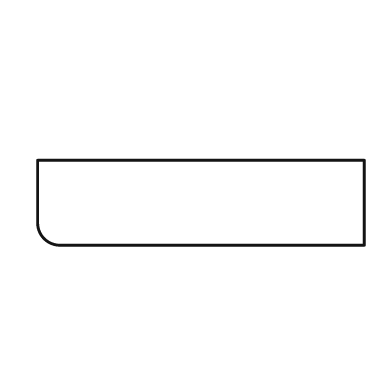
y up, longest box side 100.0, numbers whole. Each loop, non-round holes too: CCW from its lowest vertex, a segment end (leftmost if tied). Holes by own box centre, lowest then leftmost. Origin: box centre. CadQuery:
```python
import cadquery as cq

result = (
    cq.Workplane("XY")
    .moveTo(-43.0, -13.0)
    .lineTo(50.0, -13.0)
    .lineTo(50.0, 13.0)
    .lineTo(-50.0, 13.0)
    .lineTo(-50.0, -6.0)
    .threePointArc((-48.0, -11.0), (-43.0, -13.0))
    .close()
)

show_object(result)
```